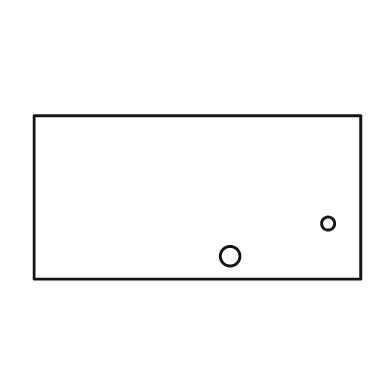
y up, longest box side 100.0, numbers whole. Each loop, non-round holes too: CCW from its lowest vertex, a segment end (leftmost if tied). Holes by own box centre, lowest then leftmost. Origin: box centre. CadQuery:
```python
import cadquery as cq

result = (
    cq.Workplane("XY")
    .moveTo(-50.0, -25.0)
    .lineTo(50.0, -25.0)
    .lineTo(50.0, 25.0)
    .lineTo(-50.0, 25.0)
    .close()
    .moveTo(10.0, -18.0)
    .circle(3.0)
    .moveTo(40.0, -8.0)
    .circle(2.0)
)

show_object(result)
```